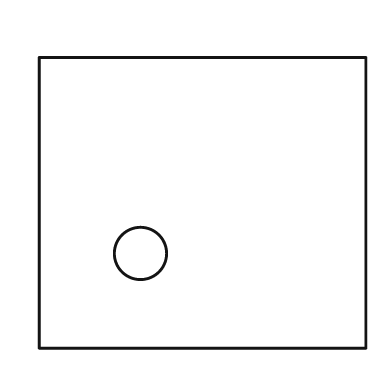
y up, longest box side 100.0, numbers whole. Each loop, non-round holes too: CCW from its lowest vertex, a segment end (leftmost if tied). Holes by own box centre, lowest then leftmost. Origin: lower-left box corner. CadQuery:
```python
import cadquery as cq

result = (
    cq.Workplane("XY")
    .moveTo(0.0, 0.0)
    .lineTo(100.0, 0.0)
    .lineTo(100.0, 89.0)
    .lineTo(0.0, 89.0)
    .close()
    .moveTo(31.0, 29.0)
    .circle(8.0)
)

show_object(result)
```